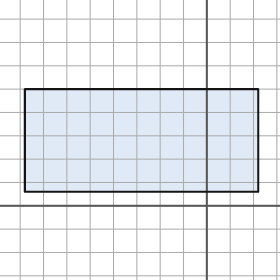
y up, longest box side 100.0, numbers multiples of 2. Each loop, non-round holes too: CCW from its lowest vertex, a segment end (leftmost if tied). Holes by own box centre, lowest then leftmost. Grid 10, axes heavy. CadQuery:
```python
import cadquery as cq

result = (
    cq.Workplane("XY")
    .moveTo(-78.0, 6.0)
    .lineTo(22.0, 6.0)
    .lineTo(22.0, 50.0)
    .lineTo(-78.0, 50.0)
    .close()
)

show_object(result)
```